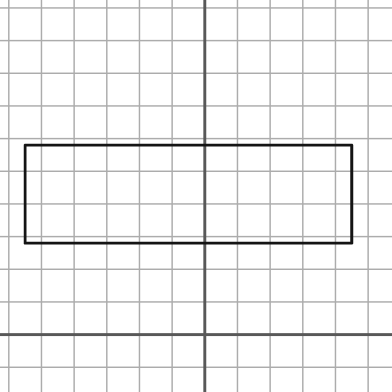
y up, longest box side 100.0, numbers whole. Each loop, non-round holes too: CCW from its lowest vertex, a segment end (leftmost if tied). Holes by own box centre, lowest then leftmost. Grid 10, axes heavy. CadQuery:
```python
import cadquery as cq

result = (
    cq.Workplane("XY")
    .moveTo(-55.0, 28.0)
    .lineTo(45.0, 28.0)
    .lineTo(45.0, 58.0)
    .lineTo(-55.0, 58.0)
    .close()
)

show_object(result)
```